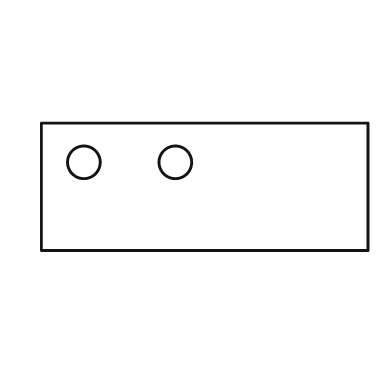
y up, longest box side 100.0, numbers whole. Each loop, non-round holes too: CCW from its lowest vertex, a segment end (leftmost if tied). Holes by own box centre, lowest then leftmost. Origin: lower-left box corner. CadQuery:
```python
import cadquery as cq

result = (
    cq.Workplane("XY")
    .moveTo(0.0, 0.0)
    .lineTo(100.0, 0.0)
    .lineTo(100.0, 39.0)
    .lineTo(0.0, 39.0)
    .close()
    .moveTo(13.0, 27.0)
    .circle(5.0)
    .moveTo(41.0, 27.0)
    .circle(5.0)
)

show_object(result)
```